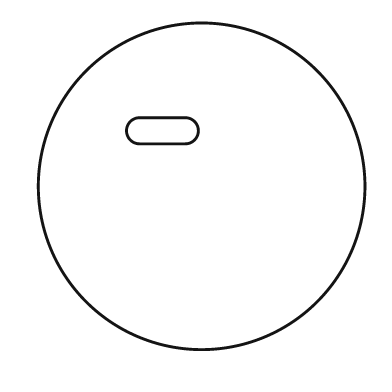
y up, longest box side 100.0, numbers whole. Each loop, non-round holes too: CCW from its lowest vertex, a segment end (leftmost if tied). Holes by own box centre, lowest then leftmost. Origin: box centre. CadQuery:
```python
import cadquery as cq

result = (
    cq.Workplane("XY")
    .moveTo(0.0, 0.0)
    .circle(50.0)
    .moveTo(-19.0, 13.0)
    .lineTo(-5.0, 13.0)
    .threePointArc((-1.0, 17.0), (-5.0, 21.0))
    .lineTo(-19.0, 21.0)
    .threePointArc((-23.0, 17.0), (-19.0, 13.0))
    .close()
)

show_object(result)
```